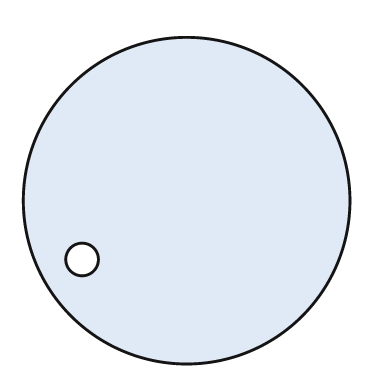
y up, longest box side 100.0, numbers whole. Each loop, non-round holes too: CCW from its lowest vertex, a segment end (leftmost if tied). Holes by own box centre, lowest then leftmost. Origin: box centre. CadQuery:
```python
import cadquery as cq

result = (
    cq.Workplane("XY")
    .moveTo(0.0, 0.0)
    .circle(50.0)
    .moveTo(-32.0, -18.0)
    .circle(5.0)
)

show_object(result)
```